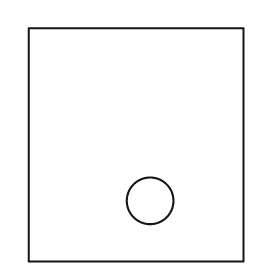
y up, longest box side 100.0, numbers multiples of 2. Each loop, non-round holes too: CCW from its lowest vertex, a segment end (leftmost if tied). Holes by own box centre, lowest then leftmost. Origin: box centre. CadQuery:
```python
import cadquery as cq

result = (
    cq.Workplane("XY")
    .moveTo(-46.0, -50.0)
    .lineTo(46.0, -50.0)
    .lineTo(46.0, 50.0)
    .lineTo(-46.0, 50.0)
    .close()
    .moveTo(6.0, -24.0)
    .circle(10.0)
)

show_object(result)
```